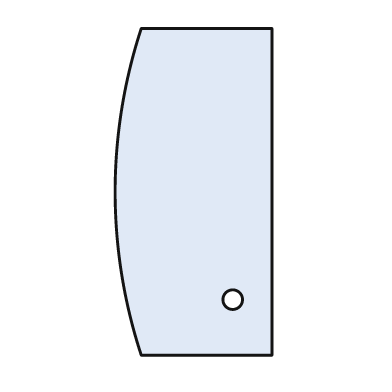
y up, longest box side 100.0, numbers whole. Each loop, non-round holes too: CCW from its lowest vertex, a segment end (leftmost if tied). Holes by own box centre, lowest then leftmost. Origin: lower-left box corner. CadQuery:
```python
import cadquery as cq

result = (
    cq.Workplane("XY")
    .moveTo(8.0, 0.0)
    .lineTo(48.0, 0.0)
    .lineTo(48.0, 100.0)
    .lineTo(8.0, 100.0)
    .threePointArc((0.0, 50.0), (8.0, 0.0))
    .close()
    .moveTo(36.0, 17.0)
    .circle(3.0)
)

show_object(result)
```